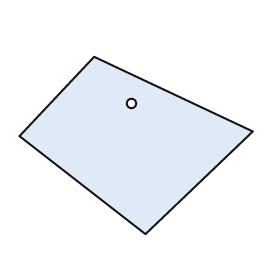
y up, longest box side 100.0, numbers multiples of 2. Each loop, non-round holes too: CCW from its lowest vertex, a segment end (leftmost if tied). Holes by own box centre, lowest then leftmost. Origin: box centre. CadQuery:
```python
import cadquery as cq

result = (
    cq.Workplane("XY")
    .moveTo(4.0, -38.0)
    .lineTo(50.0, 6.0)
    .lineTo(-18.0, 38.0)
    .lineTo(-50.0, 4.0)
    .close()
    .moveTo(-2.0, 18.0)
    .circle(2.0)
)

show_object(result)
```